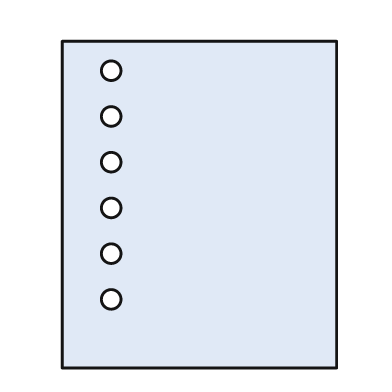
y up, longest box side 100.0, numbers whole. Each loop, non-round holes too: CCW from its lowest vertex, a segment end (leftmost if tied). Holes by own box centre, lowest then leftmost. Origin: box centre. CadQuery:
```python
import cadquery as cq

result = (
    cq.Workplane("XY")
    .moveTo(-42.0, -50.0)
    .lineTo(42.0, -50.0)
    .lineTo(42.0, 50.0)
    .lineTo(-42.0, 50.0)
    .close()
    .moveTo(-27.0, -29.0)
    .circle(3.0)
    .moveTo(-27.0, -15.0)
    .circle(3.0)
    .moveTo(-27.0, -1.0)
    .circle(3.0)
    .moveTo(-27.0, 13.0)
    .circle(3.0)
    .moveTo(-27.0, 27.0)
    .circle(3.0)
    .moveTo(-27.0, 41.0)
    .circle(3.0)
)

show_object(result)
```